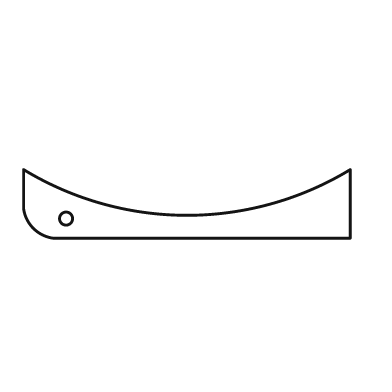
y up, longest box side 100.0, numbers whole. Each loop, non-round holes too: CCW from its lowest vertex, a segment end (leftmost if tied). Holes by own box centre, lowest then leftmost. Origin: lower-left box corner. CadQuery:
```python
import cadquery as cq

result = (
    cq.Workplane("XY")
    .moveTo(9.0, 0.0)
    .lineTo(100.0, 0.0)
    .lineTo(100.0, 21.0)
    .threePointArc((50.0, 7.0), (0.0, 21.0))
    .lineTo(0.0, 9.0)
    .threePointArc((3.0, 3.0), (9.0, 0.0))
    .close()
    .moveTo(13.0, 6.0)
    .circle(2.0)
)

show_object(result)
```